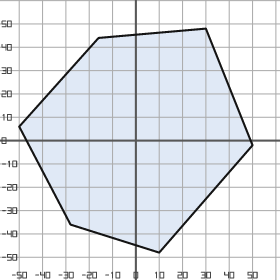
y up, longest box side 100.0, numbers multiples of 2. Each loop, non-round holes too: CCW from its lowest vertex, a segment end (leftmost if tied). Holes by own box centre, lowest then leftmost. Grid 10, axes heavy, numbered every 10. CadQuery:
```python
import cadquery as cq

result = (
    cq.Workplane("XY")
    .moveTo(10.0, -48.0)
    .lineTo(50.0, -2.0)
    .lineTo(30.0, 48.0)
    .lineTo(-16.0, 44.0)
    .lineTo(-50.0, 6.0)
    .lineTo(-28.0, -36.0)
    .close()
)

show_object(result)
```